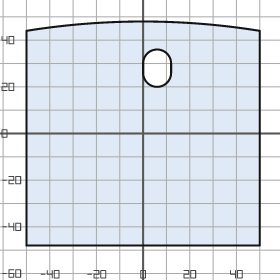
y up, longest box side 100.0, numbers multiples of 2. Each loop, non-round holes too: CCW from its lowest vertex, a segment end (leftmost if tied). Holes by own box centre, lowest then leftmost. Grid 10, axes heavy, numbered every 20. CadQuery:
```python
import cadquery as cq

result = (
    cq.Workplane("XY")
    .moveTo(-50.0, -48.0)
    .lineTo(50.0, -48.0)
    .lineTo(50.0, 44.0)
    .threePointArc((0.0, 48.0), (-50.0, 44.0))
    .close()
    .moveTo(0.0, 26.0)
    .threePointArc((6.0, 20.0), (12.0, 26.0))
    .lineTo(12.0, 30.0)
    .threePointArc((6.0, 36.0), (0.0, 30.0))
    .close()
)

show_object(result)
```